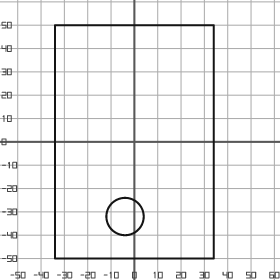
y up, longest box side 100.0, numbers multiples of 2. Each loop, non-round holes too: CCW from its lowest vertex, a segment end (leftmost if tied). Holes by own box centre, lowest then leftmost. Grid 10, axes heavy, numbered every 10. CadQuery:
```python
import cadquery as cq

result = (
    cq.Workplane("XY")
    .moveTo(-34.0, -50.0)
    .lineTo(34.0, -50.0)
    .lineTo(34.0, 50.0)
    .lineTo(-34.0, 50.0)
    .close()
    .moveTo(-4.0, -32.0)
    .circle(8.0)
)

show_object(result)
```